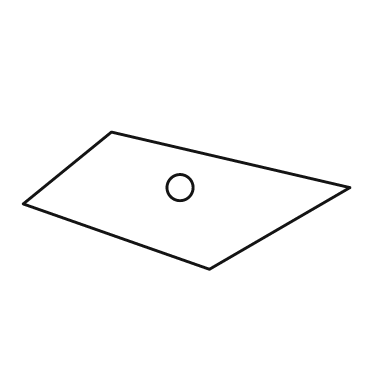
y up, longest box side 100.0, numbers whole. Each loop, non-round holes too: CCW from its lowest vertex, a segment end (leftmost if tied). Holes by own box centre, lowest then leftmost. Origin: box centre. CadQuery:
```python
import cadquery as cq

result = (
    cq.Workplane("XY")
    .moveTo(7.0, -21.0)
    .lineTo(50.0, 4.0)
    .lineTo(-23.0, 21.0)
    .lineTo(-50.0, -1.0)
    .close()
    .moveTo(-2.0, 4.0)
    .circle(4.0)
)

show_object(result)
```